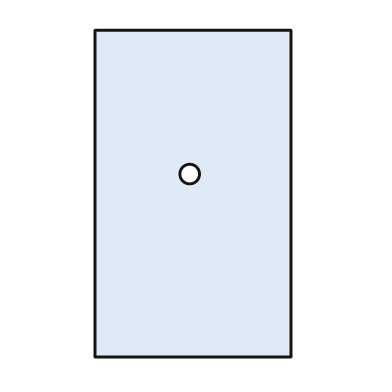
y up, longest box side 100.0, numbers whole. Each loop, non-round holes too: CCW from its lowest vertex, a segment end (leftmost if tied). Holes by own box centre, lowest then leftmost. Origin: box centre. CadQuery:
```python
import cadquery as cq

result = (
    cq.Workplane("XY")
    .moveTo(-30.0, -50.0)
    .lineTo(30.0, -50.0)
    .lineTo(30.0, 50.0)
    .lineTo(-30.0, 50.0)
    .close()
    .moveTo(-1.0, 6.0)
    .circle(3.0)
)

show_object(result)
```